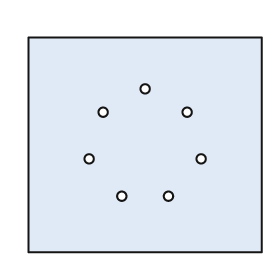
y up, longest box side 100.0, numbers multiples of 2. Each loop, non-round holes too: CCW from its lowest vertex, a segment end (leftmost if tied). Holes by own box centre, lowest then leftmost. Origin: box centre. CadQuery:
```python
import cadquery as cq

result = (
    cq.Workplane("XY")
    .moveTo(-50.0, -46.0)
    .lineTo(50.0, -46.0)
    .lineTo(50.0, 46.0)
    .lineTo(-50.0, 46.0)
    .close()
    .moveTo(-10.0, -22.0)
    .circle(2.0)
    .moveTo(10.0, -22.0)
    .circle(2.0)
    .moveTo(-24.0, -6.0)
    .circle(2.0)
    .moveTo(24.0, -6.0)
    .circle(2.0)
    .moveTo(-18.0, 14.0)
    .circle(2.0)
    .moveTo(18.0, 14.0)
    .circle(2.0)
    .moveTo(0.0, 24.0)
    .circle(2.0)
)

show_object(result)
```